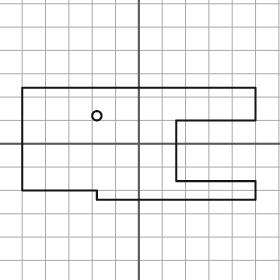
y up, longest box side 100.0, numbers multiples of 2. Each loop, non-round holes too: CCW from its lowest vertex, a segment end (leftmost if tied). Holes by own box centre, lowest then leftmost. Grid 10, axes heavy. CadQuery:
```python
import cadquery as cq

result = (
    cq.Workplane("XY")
    .moveTo(-18.0, -24.0)
    .lineTo(50.0, -24.0)
    .lineTo(50.0, -16.0)
    .lineTo(16.0, -16.0)
    .lineTo(16.0, 10.0)
    .lineTo(50.0, 10.0)
    .lineTo(50.0, 24.0)
    .lineTo(-50.0, 24.0)
    .lineTo(-50.0, -20.0)
    .lineTo(-18.0, -20.0)
    .close()
    .moveTo(-18.0, 12.0)
    .circle(2.0)
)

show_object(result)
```